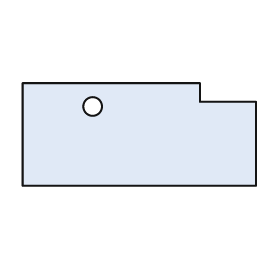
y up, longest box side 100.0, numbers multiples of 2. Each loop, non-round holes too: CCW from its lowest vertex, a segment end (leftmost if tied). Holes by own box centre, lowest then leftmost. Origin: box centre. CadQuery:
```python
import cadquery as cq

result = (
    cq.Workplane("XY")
    .moveTo(-50.0, -22.0)
    .lineTo(50.0, -22.0)
    .lineTo(50.0, 14.0)
    .lineTo(26.0, 14.0)
    .lineTo(26.0, 22.0)
    .lineTo(-50.0, 22.0)
    .close()
    .moveTo(-20.0, 12.0)
    .circle(4.0)
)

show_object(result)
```